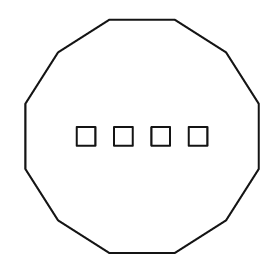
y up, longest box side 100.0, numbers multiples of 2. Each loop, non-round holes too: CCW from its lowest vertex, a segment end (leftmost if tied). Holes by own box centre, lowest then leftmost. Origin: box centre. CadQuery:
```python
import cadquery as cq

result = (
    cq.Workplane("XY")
    .moveTo(-14.0, -50.0)
    .lineTo(14.0, -50.0)
    .lineTo(36.0, -36.0)
    .lineTo(50.0, -14.0)
    .lineTo(50.0, 14.0)
    .lineTo(36.0, 36.0)
    .lineTo(14.0, 50.0)
    .lineTo(-14.0, 50.0)
    .lineTo(-36.0, 36.0)
    .lineTo(-50.0, 14.0)
    .lineTo(-50.0, -14.0)
    .lineTo(-36.0, -36.0)
    .close()
    .moveTo(-28.0, -4.0)
    .lineTo(-20.0, -4.0)
    .lineTo(-20.0, 4.0)
    .lineTo(-28.0, 4.0)
    .close()
    .moveTo(-12.0, -4.0)
    .lineTo(-4.0, -4.0)
    .lineTo(-4.0, 4.0)
    .lineTo(-12.0, 4.0)
    .close()
    .moveTo(4.0, -4.0)
    .lineTo(12.0, -4.0)
    .lineTo(12.0, 4.0)
    .lineTo(4.0, 4.0)
    .close()
    .moveTo(20.0, -4.0)
    .lineTo(28.0, -4.0)
    .lineTo(28.0, 4.0)
    .lineTo(20.0, 4.0)
    .close()
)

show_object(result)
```